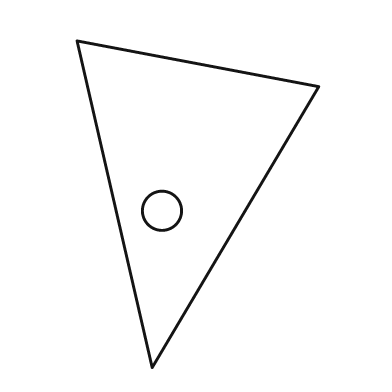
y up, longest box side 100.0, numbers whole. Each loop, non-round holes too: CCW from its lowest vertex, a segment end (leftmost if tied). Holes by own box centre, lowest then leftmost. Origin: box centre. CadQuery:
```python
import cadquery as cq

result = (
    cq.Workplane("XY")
    .moveTo(-14.0, -50.0)
    .lineTo(37.0, 36.0)
    .lineTo(-37.0, 50.0)
    .close()
    .moveTo(-11.0, -2.0)
    .circle(6.0)
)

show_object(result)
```